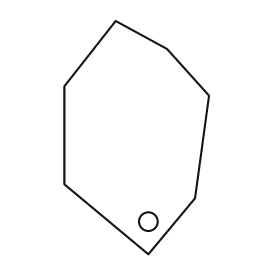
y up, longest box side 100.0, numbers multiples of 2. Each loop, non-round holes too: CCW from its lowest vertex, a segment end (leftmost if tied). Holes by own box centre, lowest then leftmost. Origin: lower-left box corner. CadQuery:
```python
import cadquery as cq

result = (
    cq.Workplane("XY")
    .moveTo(36.0, 0.0)
    .lineTo(56.0, 24.0)
    .lineTo(62.0, 68.0)
    .lineTo(44.0, 88.0)
    .lineTo(22.0, 100.0)
    .lineTo(0.0, 72.0)
    .lineTo(0.0, 30.0)
    .close()
    .moveTo(36.0, 14.0)
    .circle(4.0)
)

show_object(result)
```